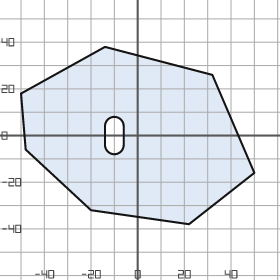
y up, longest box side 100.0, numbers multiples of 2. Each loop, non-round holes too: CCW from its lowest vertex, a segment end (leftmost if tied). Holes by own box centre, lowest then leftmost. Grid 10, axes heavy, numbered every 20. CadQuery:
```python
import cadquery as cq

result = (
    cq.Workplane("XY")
    .moveTo(22.0, -38.0)
    .lineTo(50.0, -16.0)
    .lineTo(32.0, 26.0)
    .lineTo(-14.0, 38.0)
    .lineTo(-50.0, 18.0)
    .lineTo(-48.0, -6.0)
    .lineTo(-20.0, -32.0)
    .close()
    .moveTo(-14.0, -4.0)
    .threePointArc((-10.0, -8.0), (-6.0, -4.0))
    .lineTo(-6.0, 4.0)
    .threePointArc((-10.0, 8.0), (-14.0, 4.0))
    .close()
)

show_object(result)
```